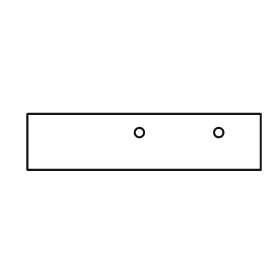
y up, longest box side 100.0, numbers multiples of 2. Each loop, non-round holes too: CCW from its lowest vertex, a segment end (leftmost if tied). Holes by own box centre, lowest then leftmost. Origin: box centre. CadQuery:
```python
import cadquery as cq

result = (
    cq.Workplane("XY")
    .moveTo(-50.0, -12.0)
    .lineTo(50.0, -12.0)
    .lineTo(50.0, 12.0)
    .lineTo(-50.0, 12.0)
    .close()
    .moveTo(-2.0, 4.0)
    .circle(2.0)
    .moveTo(32.0, 4.0)
    .circle(2.0)
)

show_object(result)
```